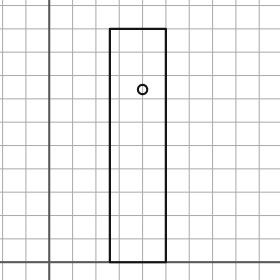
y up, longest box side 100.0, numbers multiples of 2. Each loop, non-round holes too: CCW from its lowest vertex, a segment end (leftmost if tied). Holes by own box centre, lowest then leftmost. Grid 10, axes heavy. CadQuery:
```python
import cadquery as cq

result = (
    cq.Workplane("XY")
    .moveTo(26.0, 0.0)
    .lineTo(50.0, 0.0)
    .lineTo(50.0, 100.0)
    .lineTo(26.0, 100.0)
    .close()
    .moveTo(40.0, 74.0)
    .circle(2.0)
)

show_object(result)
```